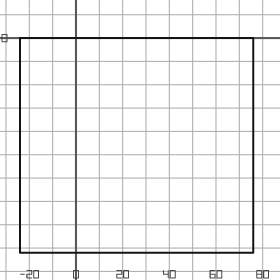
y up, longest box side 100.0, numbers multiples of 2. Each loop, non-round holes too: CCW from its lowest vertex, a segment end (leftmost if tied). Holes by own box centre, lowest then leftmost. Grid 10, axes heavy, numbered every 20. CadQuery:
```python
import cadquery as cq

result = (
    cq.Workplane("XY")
    .moveTo(-24.0, -92.0)
    .lineTo(76.0, -92.0)
    .lineTo(76.0, 0.0)
    .lineTo(-24.0, 0.0)
    .close()
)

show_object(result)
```